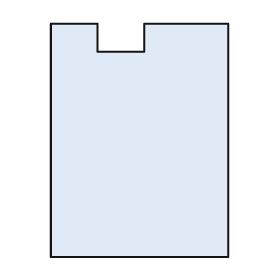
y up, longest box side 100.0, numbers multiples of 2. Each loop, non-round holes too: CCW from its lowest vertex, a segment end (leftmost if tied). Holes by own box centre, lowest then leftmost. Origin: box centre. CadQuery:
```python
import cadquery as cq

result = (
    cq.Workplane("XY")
    .moveTo(-38.0, -50.0)
    .lineTo(38.0, -50.0)
    .lineTo(38.0, 50.0)
    .lineTo(2.0, 50.0)
    .lineTo(2.0, 38.0)
    .lineTo(-18.0, 38.0)
    .lineTo(-18.0, 50.0)
    .lineTo(-38.0, 50.0)
    .close()
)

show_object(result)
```